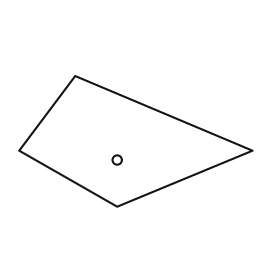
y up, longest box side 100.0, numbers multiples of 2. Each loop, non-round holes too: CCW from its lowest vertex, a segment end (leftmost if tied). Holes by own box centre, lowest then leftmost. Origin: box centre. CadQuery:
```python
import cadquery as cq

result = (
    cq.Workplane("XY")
    .moveTo(-8.0, -28.0)
    .lineTo(50.0, -4.0)
    .lineTo(-26.0, 28.0)
    .lineTo(-50.0, -4.0)
    .close()
    .moveTo(-8.0, -8.0)
    .circle(2.0)
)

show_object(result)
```